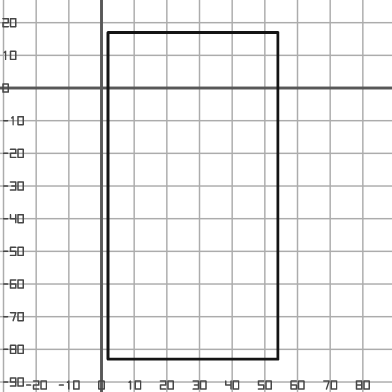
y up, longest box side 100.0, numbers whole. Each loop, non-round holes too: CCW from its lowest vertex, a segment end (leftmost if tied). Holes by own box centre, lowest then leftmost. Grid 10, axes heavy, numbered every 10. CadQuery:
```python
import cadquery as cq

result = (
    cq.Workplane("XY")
    .moveTo(2.0, -83.0)
    .lineTo(54.0, -83.0)
    .lineTo(54.0, 17.0)
    .lineTo(2.0, 17.0)
    .close()
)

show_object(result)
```